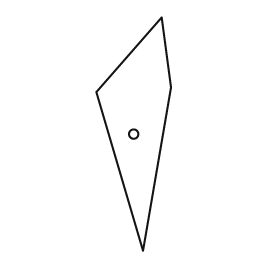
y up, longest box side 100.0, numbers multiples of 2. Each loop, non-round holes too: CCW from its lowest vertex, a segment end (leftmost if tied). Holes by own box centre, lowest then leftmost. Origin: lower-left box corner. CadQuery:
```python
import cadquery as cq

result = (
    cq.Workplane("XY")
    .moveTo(20.0, 0.0)
    .lineTo(32.0, 70.0)
    .lineTo(28.0, 100.0)
    .lineTo(0.0, 68.0)
    .close()
    .moveTo(16.0, 50.0)
    .circle(2.0)
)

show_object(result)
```